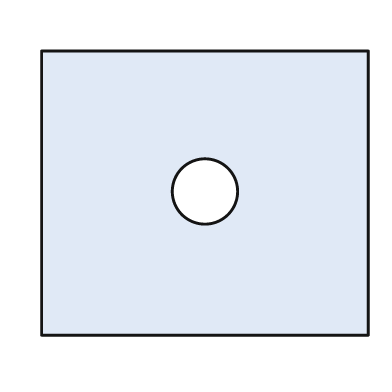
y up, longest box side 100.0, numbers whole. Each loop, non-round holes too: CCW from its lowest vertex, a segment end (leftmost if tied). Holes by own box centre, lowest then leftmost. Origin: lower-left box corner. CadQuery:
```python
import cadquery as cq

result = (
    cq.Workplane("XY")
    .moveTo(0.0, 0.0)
    .lineTo(100.0, 0.0)
    .lineTo(100.0, 87.0)
    .lineTo(0.0, 87.0)
    .close()
    .moveTo(50.0, 44.0)
    .circle(10.0)
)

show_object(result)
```